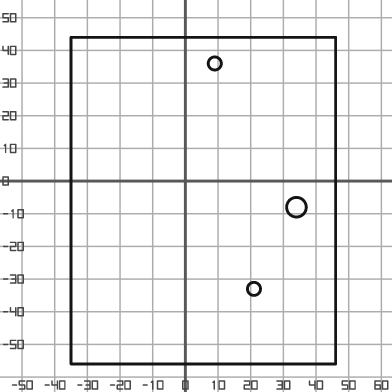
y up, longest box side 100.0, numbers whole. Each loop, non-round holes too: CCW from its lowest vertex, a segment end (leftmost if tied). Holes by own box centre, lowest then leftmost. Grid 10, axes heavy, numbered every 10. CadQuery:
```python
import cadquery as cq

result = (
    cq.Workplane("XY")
    .moveTo(-35.0, -56.0)
    .lineTo(46.0, -56.0)
    .lineTo(46.0, 44.0)
    .lineTo(-35.0, 44.0)
    .close()
    .moveTo(21.0, -33.0)
    .circle(2.0)
    .moveTo(34.0, -8.0)
    .circle(3.0)
    .moveTo(9.0, 36.0)
    .circle(2.0)
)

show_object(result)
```